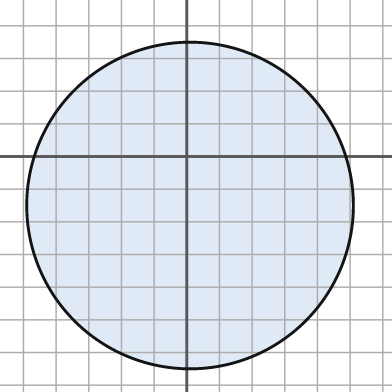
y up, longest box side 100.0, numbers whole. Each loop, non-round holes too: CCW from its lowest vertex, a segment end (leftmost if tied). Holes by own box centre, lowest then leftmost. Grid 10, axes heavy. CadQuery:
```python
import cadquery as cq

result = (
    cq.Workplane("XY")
    .moveTo(1.0, -15.0)
    .circle(50.0)
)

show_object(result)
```